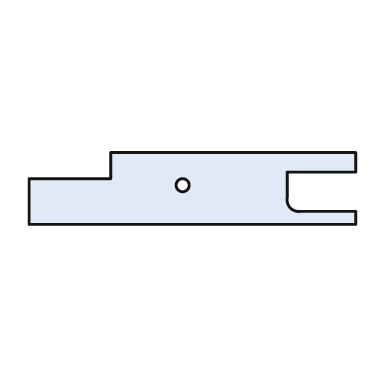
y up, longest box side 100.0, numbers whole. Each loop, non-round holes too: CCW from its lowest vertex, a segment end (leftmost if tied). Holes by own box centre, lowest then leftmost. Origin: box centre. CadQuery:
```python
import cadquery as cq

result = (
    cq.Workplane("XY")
    .moveTo(-50.0, -11.0)
    .lineTo(50.0, -11.0)
    .lineTo(50.0, -7.0)
    .lineTo(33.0, -7.0)
    .threePointArc((30.0, -6.0), (29.0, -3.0))
    .lineTo(29.0, 5.0)
    .lineTo(50.0, 5.0)
    .lineTo(50.0, 11.0)
    .lineTo(-25.0, 11.0)
    .lineTo(-25.0, 3.0)
    .lineTo(-50.0, 3.0)
    .close()
    .moveTo(-3.0, 1.0)
    .circle(2.0)
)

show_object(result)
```